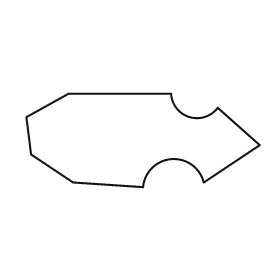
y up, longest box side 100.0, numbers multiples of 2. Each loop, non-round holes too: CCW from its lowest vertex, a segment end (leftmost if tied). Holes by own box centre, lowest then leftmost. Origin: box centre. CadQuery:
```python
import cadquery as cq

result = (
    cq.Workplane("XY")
    .moveTo(0.0, -20.0)
    .threePointArc((12.0, -8.0), (26.0, -18.0))
    .lineTo(50.0, -2.0)
    .lineTo(32.0, 14.0)
    .threePointArc((20.0, 10.0), (12.0, 20.0))
    .lineTo(-32.0, 20.0)
    .lineTo(-50.0, 10.0)
    .lineTo(-48.0, -6.0)
    .lineTo(-30.0, -18.0)
    .close()
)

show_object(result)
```